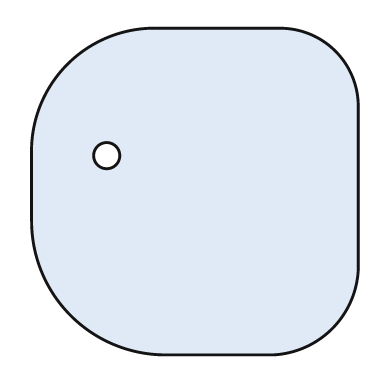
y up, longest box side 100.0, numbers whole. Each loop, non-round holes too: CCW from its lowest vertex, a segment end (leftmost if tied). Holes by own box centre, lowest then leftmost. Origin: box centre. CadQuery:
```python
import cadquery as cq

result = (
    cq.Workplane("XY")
    .moveTo(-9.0, -50.0)
    .lineTo(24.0, -50.0)
    .threePointArc((42.0, -42.0), (50.0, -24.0))
    .lineTo(50.0, 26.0)
    .threePointArc((43.0, 43.0), (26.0, 50.0))
    .lineTo(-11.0, 50.0)
    .threePointArc((-39.0, 39.0), (-50.0, 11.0))
    .lineTo(-50.0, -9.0)
    .threePointArc((-38.0, -38.0), (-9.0, -50.0))
    .close()
    .moveTo(-27.0, 11.0)
    .circle(4.0)
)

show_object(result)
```